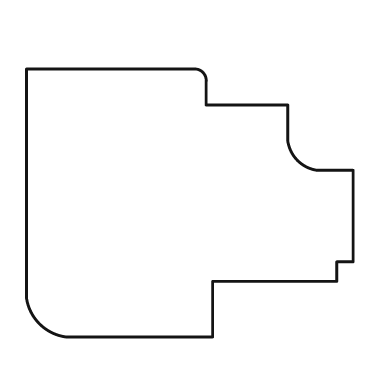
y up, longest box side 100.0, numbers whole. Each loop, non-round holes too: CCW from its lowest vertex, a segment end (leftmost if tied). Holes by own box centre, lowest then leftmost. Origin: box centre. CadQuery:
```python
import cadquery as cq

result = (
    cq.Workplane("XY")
    .moveTo(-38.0, -41.0)
    .lineTo(7.0, -41.0)
    .lineTo(7.0, -24.0)
    .lineTo(45.0, -24.0)
    .lineTo(45.0, -18.0)
    .lineTo(50.0, -18.0)
    .lineTo(50.0, 10.0)
    .lineTo(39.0, 10.0)
    .threePointArc((33.0, 13.0), (30.0, 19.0))
    .lineTo(30.0, 30.0)
    .lineTo(5.0, 30.0)
    .lineTo(5.0, 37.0)
    .threePointArc((4.0, 40.0), (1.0, 41.0))
    .lineTo(-50.0, 41.0)
    .lineTo(-50.0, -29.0)
    .threePointArc((-46.0, -37.0), (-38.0, -41.0))
    .close()
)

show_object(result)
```